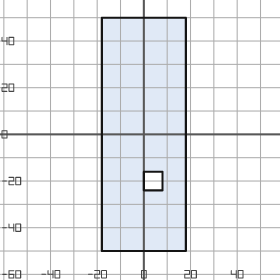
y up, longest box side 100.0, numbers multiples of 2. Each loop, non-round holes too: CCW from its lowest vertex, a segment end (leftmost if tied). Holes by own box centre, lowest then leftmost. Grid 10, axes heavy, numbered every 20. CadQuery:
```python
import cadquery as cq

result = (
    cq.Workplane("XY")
    .moveTo(-18.0, -50.0)
    .lineTo(18.0, -50.0)
    .lineTo(18.0, 50.0)
    .lineTo(-18.0, 50.0)
    .close()
    .moveTo(0.0, -24.0)
    .lineTo(8.0, -24.0)
    .lineTo(8.0, -16.0)
    .lineTo(0.0, -16.0)
    .close()
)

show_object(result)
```